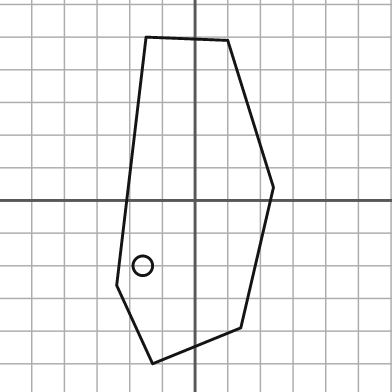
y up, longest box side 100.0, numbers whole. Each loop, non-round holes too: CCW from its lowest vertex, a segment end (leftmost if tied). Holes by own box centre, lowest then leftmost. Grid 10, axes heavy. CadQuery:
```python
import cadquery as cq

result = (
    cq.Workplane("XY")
    .moveTo(-13.0, -50.0)
    .lineTo(14.0, -39.0)
    .lineTo(24.0, 4.0)
    .lineTo(10.0, 49.0)
    .lineTo(-15.0, 50.0)
    .lineTo(-24.0, -26.0)
    .close()
    .moveTo(-16.0, -20.0)
    .circle(3.0)
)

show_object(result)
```